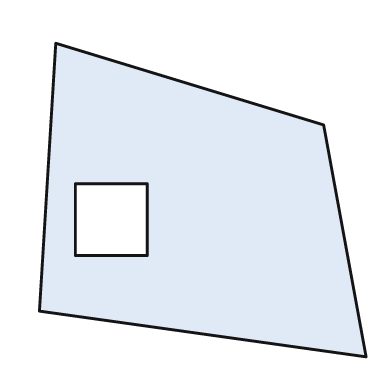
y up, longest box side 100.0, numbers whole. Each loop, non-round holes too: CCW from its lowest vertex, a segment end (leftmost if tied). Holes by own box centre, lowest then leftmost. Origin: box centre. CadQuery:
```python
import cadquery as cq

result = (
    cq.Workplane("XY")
    .moveTo(50.0, -48.0)
    .lineTo(37.0, 23.0)
    .lineTo(-45.0, 48.0)
    .lineTo(-50.0, -34.0)
    .close()
    .moveTo(-39.0, -17.0)
    .lineTo(-17.0, -17.0)
    .lineTo(-17.0, 5.0)
    .lineTo(-39.0, 5.0)
    .close()
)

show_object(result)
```